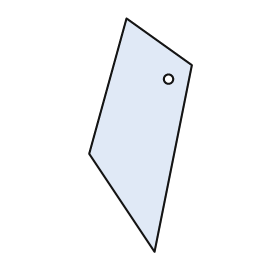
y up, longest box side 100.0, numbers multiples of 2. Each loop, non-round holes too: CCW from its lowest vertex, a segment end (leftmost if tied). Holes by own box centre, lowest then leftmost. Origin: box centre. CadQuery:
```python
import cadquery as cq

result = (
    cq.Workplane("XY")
    .moveTo(6.0, -50.0)
    .lineTo(22.0, 30.0)
    .lineTo(-6.0, 50.0)
    .lineTo(-22.0, -8.0)
    .close()
    .moveTo(12.0, 24.0)
    .circle(2.0)
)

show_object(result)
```